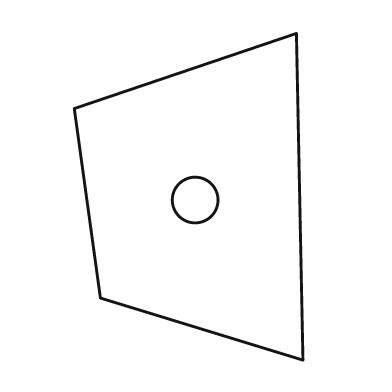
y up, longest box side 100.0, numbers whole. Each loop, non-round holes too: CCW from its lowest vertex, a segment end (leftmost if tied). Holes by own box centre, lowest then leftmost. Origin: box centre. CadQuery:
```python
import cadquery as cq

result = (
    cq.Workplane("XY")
    .moveTo(35.0, -50.0)
    .lineTo(33.0, 50.0)
    .lineTo(-35.0, 27.0)
    .lineTo(-27.0, -31.0)
    .close()
    .moveTo(2.0, -1.0)
    .circle(7.0)
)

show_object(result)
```